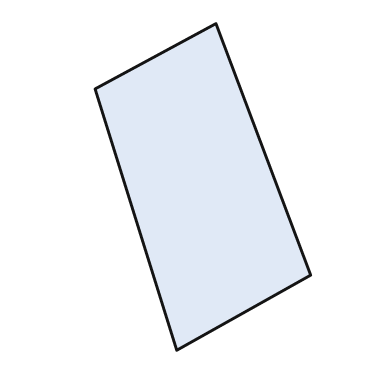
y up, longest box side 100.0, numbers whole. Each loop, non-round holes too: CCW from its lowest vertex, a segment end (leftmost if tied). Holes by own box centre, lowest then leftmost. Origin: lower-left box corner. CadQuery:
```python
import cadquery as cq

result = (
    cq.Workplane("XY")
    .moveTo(25.0, 0.0)
    .lineTo(66.0, 23.0)
    .lineTo(37.0, 100.0)
    .lineTo(0.0, 80.0)
    .close()
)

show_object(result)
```